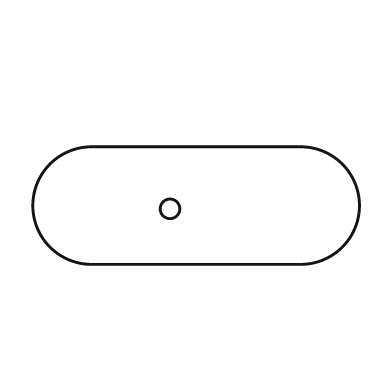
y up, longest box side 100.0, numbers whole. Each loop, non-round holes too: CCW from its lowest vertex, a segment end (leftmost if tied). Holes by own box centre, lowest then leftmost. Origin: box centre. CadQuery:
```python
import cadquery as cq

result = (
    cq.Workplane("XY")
    .moveTo(-32.0, -18.0)
    .lineTo(32.0, -18.0)
    .threePointArc((50.0, 0.0), (32.0, 18.0))
    .lineTo(-32.0, 18.0)
    .threePointArc((-50.0, 0.0), (-32.0, -18.0))
    .close()
    .moveTo(-8.0, -1.0)
    .circle(3.0)
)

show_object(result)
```